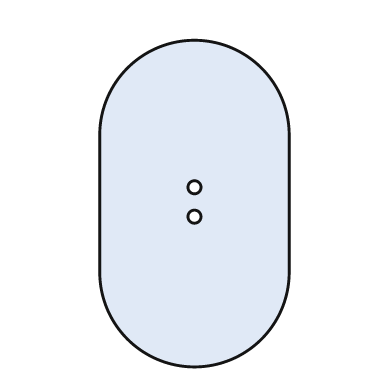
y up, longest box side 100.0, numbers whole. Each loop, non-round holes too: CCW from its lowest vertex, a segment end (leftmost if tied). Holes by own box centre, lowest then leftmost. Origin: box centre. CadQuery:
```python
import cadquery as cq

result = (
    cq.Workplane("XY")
    .moveTo(-29.0, -21.0)
    .threePointArc((0.0, -50.0), (29.0, -21.0))
    .lineTo(29.0, 21.0)
    .threePointArc((0.0, 50.0), (-29.0, 21.0))
    .close()
    .moveTo(0.0, -4.0)
    .circle(2.0)
    .moveTo(0.0, 5.0)
    .circle(2.0)
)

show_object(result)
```